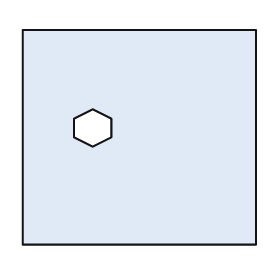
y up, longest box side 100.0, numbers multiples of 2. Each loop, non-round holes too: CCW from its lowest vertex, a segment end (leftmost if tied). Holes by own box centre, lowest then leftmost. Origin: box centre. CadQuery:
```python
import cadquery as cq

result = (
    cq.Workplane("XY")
    .moveTo(-50.0, -46.0)
    .lineTo(50.0, -46.0)
    .lineTo(50.0, 46.0)
    .lineTo(-50.0, 46.0)
    .close()
    .moveTo(-20.0, -4.0)
    .lineTo(-12.0, 0.0)
    .lineTo(-12.0, 8.0)
    .lineTo(-20.0, 12.0)
    .lineTo(-28.0, 8.0)
    .lineTo(-28.0, 0.0)
    .close()
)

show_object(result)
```